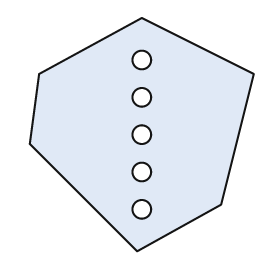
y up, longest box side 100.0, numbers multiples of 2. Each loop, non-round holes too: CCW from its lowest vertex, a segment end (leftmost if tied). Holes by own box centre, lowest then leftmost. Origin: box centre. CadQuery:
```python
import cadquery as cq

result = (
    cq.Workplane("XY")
    .moveTo(-2.0, -50.0)
    .lineTo(34.0, -30.0)
    .lineTo(48.0, 26.0)
    .lineTo(0.0, 50.0)
    .lineTo(-44.0, 26.0)
    .lineTo(-48.0, -4.0)
    .close()
    .moveTo(0.0, -32.0)
    .circle(4.0)
    .moveTo(0.0, -16.0)
    .circle(4.0)
    .moveTo(0.0, 0.0)
    .circle(4.0)
    .moveTo(0.0, 16.0)
    .circle(4.0)
    .moveTo(0.0, 32.0)
    .circle(4.0)
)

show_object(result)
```